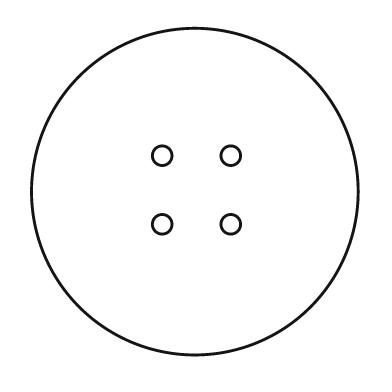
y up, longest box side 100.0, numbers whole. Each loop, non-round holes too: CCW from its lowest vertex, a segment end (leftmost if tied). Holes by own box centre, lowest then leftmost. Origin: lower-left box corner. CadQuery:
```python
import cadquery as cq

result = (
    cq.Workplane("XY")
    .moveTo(50.0, 50.0)
    .circle(50.0)
    .moveTo(40.0, 40.0)
    .circle(3.0)
    .moveTo(61.0, 40.0)
    .circle(3.0)
    .moveTo(40.0, 61.0)
    .circle(3.0)
    .moveTo(61.0, 61.0)
    .circle(3.0)
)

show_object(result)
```